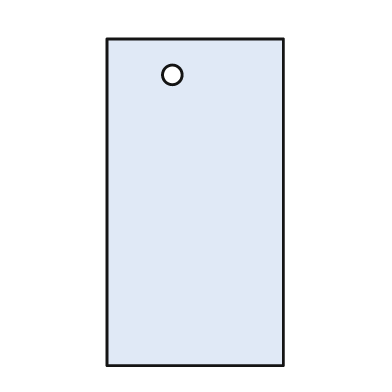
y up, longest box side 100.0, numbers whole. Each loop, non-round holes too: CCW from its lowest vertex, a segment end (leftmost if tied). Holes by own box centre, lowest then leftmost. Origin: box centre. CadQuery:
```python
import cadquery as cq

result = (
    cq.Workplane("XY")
    .moveTo(-27.0, -50.0)
    .lineTo(27.0, -50.0)
    .lineTo(27.0, 50.0)
    .lineTo(-27.0, 50.0)
    .close()
    .moveTo(-7.0, 39.0)
    .circle(3.0)
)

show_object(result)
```